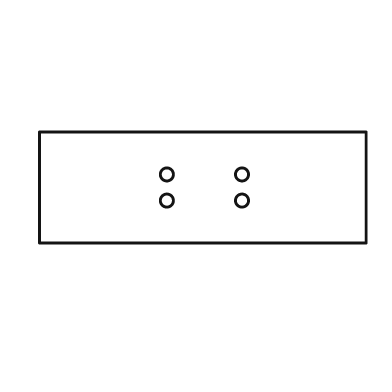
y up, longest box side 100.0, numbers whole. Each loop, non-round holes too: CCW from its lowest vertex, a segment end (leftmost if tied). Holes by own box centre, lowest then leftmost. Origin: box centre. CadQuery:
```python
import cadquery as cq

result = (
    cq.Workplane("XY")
    .moveTo(-50.0, -17.0)
    .lineTo(50.0, -17.0)
    .lineTo(50.0, 17.0)
    .lineTo(-50.0, 17.0)
    .close()
    .moveTo(-11.0, -4.0)
    .circle(2.0)
    .moveTo(12.0, -4.0)
    .circle(2.0)
    .moveTo(-11.0, 4.0)
    .circle(2.0)
    .moveTo(12.0, 4.0)
    .circle(2.0)
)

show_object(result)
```